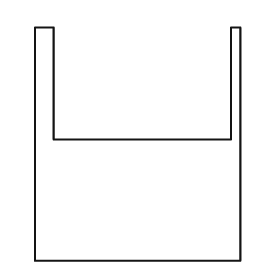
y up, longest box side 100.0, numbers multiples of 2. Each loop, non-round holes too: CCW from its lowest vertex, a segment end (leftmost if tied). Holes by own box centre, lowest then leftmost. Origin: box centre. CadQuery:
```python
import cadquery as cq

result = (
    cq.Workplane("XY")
    .moveTo(-44.0, -50.0)
    .lineTo(44.0, -50.0)
    .lineTo(44.0, 50.0)
    .lineTo(40.0, 50.0)
    .lineTo(40.0, 2.0)
    .lineTo(-36.0, 2.0)
    .lineTo(-36.0, 50.0)
    .lineTo(-44.0, 50.0)
    .close()
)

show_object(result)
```